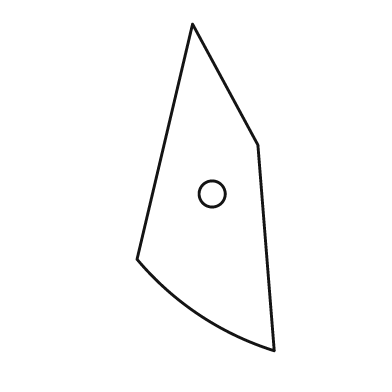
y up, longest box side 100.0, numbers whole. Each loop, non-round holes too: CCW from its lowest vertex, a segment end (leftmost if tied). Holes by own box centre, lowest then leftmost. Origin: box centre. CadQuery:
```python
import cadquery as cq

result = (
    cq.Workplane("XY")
    .moveTo(21.0, -50.0)
    .lineTo(16.0, 13.0)
    .lineTo(-4.0, 50.0)
    .lineTo(-21.0, -22.0)
    .threePointArc((-2.0, -39.0), (21.0, -50.0))
    .close()
    .moveTo(2.0, -2.0)
    .circle(4.0)
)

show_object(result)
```